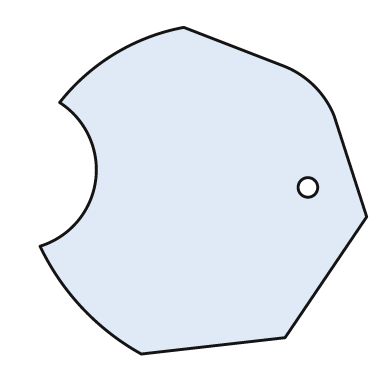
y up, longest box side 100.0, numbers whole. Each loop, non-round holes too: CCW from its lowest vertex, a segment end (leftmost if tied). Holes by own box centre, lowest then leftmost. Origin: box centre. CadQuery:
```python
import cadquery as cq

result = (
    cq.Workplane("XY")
    .moveTo(-19.0, -50.0)
    .lineTo(25.0, -45.0)
    .lineTo(50.0, -8.0)
    .lineTo(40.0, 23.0)
    .threePointArc((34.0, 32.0), (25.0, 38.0))
    .lineTo(-6.0, 50.0)
    .threePointArc((-27.0, 42.0), (-44.0, 27.0))
    .threePointArc((-33.0, 3.0), (-50.0, -17.0))
    .threePointArc((-37.0, -36.0), (-19.0, -50.0))
    .close()
    .moveTo(32.0, 1.0)
    .circle(3.0)
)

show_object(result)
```